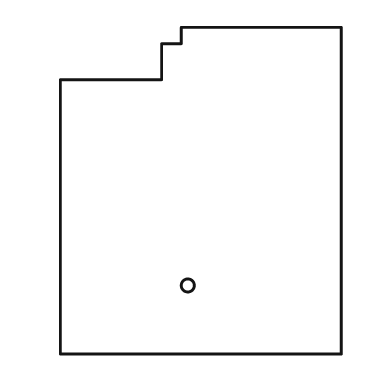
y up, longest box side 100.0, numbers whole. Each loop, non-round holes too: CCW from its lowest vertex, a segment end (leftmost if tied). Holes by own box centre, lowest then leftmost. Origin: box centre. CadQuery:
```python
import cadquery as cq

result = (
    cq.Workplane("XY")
    .moveTo(-43.0, -50.0)
    .lineTo(43.0, -50.0)
    .lineTo(43.0, 50.0)
    .lineTo(-6.0, 50.0)
    .lineTo(-6.0, 45.0)
    .lineTo(-12.0, 45.0)
    .lineTo(-12.0, 34.0)
    .lineTo(-43.0, 34.0)
    .close()
    .moveTo(-4.0, -29.0)
    .circle(2.0)
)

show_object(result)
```